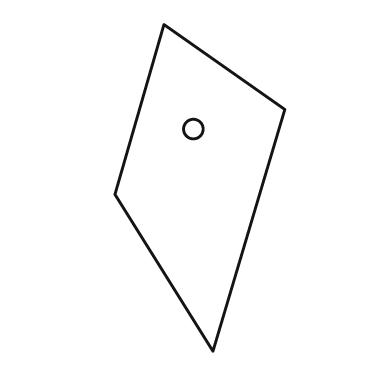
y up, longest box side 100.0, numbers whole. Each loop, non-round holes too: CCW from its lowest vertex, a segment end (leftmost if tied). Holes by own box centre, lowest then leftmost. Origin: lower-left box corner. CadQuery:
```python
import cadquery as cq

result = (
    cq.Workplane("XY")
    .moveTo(30.0, 0.0)
    .lineTo(52.0, 74.0)
    .lineTo(15.0, 100.0)
    .lineTo(0.0, 48.0)
    .close()
    .moveTo(24.0, 68.0)
    .circle(3.0)
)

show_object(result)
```